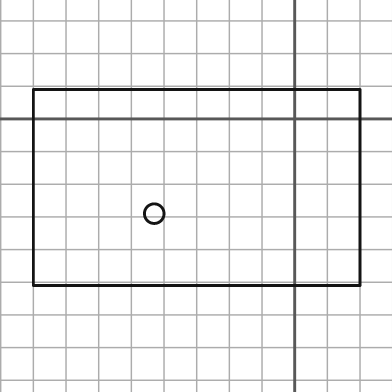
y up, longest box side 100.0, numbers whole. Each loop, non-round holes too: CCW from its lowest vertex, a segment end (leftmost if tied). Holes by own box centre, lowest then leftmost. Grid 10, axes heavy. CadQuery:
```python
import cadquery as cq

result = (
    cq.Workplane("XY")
    .moveTo(-80.0, -51.0)
    .lineTo(20.0, -51.0)
    .lineTo(20.0, 9.0)
    .lineTo(-80.0, 9.0)
    .close()
    .moveTo(-43.0, -29.0)
    .circle(3.0)
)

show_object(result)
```